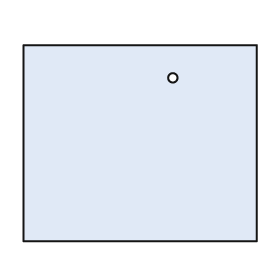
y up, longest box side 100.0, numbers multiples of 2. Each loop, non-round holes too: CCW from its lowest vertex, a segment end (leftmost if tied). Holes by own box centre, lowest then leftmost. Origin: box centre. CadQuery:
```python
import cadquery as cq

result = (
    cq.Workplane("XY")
    .moveTo(-50.0, -42.0)
    .lineTo(50.0, -42.0)
    .lineTo(50.0, 42.0)
    .lineTo(-50.0, 42.0)
    .close()
    .moveTo(14.0, 28.0)
    .circle(2.0)
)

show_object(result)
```